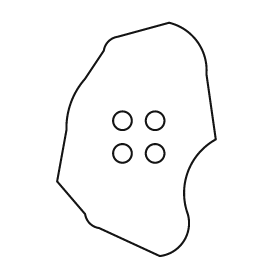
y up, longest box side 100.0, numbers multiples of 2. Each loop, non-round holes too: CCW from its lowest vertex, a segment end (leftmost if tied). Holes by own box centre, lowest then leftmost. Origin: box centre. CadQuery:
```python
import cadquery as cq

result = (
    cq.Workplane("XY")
    .moveTo(10.0, -50.0)
    .threePointArc((20.0, -44.0), (22.0, -32.0))
    .threePointArc((22.0, -14.0), (34.0, 0.0))
    .lineTo(30.0, 28.0)
    .threePointArc((26.0, 42.0), (14.0, 50.0))
    .lineTo(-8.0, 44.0)
    .threePointArc((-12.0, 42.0), (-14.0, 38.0))
    .lineTo(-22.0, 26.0)
    .threePointArc((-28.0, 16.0), (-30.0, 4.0))
    .lineTo(-34.0, -18.0)
    .lineTo(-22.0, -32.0)
    .threePointArc((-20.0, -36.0), (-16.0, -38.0))
    .close()
    .moveTo(-6.0, -6.0)
    .circle(4.0)
    .moveTo(8.0, -6.0)
    .circle(4.0)
    .moveTo(-6.0, 8.0)
    .circle(4.0)
    .moveTo(8.0, 8.0)
    .circle(4.0)
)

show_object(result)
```